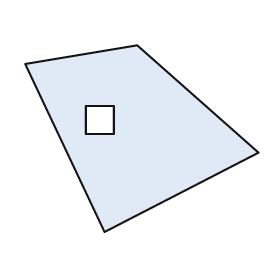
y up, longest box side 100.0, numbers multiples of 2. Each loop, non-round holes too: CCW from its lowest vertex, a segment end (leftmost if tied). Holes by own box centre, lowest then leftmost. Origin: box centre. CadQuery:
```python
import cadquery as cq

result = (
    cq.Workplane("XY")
    .moveTo(-16.0, -40.0)
    .lineTo(50.0, -6.0)
    .lineTo(-2.0, 40.0)
    .lineTo(-50.0, 32.0)
    .close()
    .moveTo(-24.0, 2.0)
    .lineTo(-12.0, 2.0)
    .lineTo(-12.0, 14.0)
    .lineTo(-24.0, 14.0)
    .close()
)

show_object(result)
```